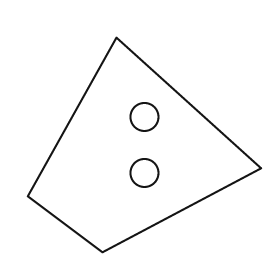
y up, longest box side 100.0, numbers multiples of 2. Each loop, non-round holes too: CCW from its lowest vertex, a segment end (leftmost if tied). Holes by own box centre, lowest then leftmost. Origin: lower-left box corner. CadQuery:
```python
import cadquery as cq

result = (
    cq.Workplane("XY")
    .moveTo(32.0, 0.0)
    .lineTo(100.0, 36.0)
    .lineTo(38.0, 92.0)
    .lineTo(0.0, 24.0)
    .close()
    .moveTo(50.0, 34.0)
    .circle(6.0)
    .moveTo(50.0, 58.0)
    .circle(6.0)
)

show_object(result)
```